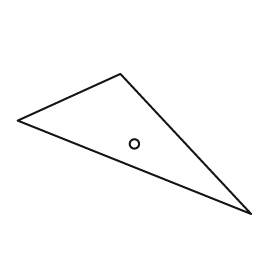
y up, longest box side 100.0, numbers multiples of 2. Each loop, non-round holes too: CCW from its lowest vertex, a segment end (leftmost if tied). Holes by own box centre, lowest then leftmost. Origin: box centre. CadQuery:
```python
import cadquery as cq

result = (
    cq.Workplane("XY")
    .moveTo(50.0, -30.0)
    .lineTo(-6.0, 30.0)
    .lineTo(-50.0, 10.0)
    .close()
    .moveTo(0.0, 0.0)
    .circle(2.0)
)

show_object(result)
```